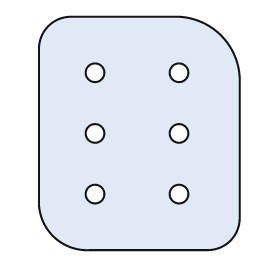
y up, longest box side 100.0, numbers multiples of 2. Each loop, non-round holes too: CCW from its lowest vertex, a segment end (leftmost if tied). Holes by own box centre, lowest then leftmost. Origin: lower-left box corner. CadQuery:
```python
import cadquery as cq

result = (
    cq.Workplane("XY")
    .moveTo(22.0, 0.0)
    .lineTo(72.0, 0.0)
    .threePointArc((82.0, 4.0), (86.0, 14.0))
    .lineTo(86.0, 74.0)
    .threePointArc((78.0, 92.0), (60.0, 100.0))
    .lineTo(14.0, 100.0)
    .threePointArc((4.0, 96.0), (0.0, 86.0))
    .lineTo(0.0, 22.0)
    .threePointArc((6.0, 6.0), (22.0, 0.0))
    .close()
    .moveTo(24.0, 24.0)
    .circle(4.0)
    .moveTo(60.0, 24.0)
    .circle(4.0)
    .moveTo(24.0, 50.0)
    .circle(4.0)
    .moveTo(60.0, 50.0)
    .circle(4.0)
    .moveTo(24.0, 76.0)
    .circle(4.0)
    .moveTo(60.0, 76.0)
    .circle(4.0)
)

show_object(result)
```